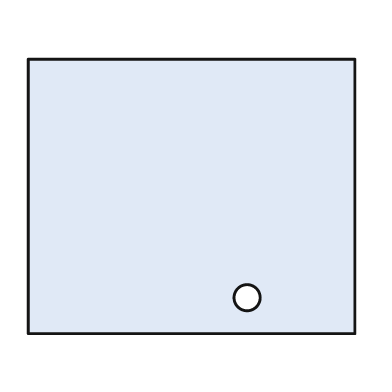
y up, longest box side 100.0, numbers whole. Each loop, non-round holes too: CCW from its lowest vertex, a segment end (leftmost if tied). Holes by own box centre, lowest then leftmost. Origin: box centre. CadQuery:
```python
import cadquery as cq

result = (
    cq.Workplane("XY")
    .moveTo(-50.0, -42.0)
    .lineTo(50.0, -42.0)
    .lineTo(50.0, 42.0)
    .lineTo(-50.0, 42.0)
    .close()
    .moveTo(17.0, -31.0)
    .circle(4.0)
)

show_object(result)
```